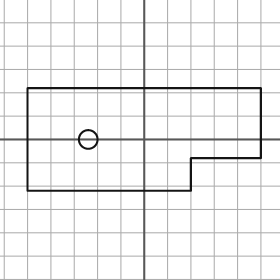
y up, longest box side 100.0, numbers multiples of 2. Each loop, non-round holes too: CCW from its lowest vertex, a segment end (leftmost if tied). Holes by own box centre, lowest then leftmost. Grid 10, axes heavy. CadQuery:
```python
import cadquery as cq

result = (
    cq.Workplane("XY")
    .moveTo(-50.0, -22.0)
    .lineTo(20.0, -22.0)
    .lineTo(20.0, -8.0)
    .lineTo(50.0, -8.0)
    .lineTo(50.0, 22.0)
    .lineTo(-50.0, 22.0)
    .close()
    .moveTo(-24.0, 0.0)
    .circle(4.0)
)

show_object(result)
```